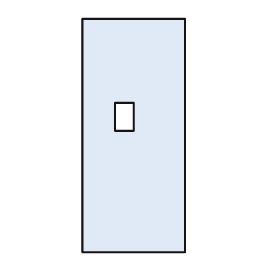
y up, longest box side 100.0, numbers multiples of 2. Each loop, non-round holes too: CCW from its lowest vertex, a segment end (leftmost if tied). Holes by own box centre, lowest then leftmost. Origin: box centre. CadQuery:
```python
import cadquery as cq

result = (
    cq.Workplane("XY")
    .moveTo(-22.0, -50.0)
    .lineTo(22.0, -50.0)
    .lineTo(22.0, 50.0)
    .lineTo(-22.0, 50.0)
    .close()
    .moveTo(-8.0, 2.0)
    .lineTo(0.0, 2.0)
    .lineTo(0.0, 14.0)
    .lineTo(-8.0, 14.0)
    .close()
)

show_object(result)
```